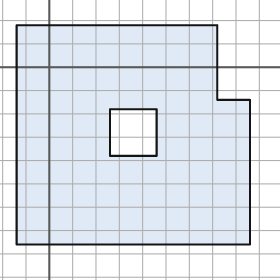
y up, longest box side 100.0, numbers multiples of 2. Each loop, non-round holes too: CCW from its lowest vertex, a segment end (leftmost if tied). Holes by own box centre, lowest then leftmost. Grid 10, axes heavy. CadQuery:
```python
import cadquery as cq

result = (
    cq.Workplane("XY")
    .moveTo(-14.0, -76.0)
    .lineTo(86.0, -76.0)
    .lineTo(86.0, -14.0)
    .lineTo(72.0, -14.0)
    .lineTo(72.0, 18.0)
    .lineTo(-14.0, 18.0)
    .close()
    .moveTo(26.0, -38.0)
    .lineTo(46.0, -38.0)
    .lineTo(46.0, -18.0)
    .lineTo(26.0, -18.0)
    .close()
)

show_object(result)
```